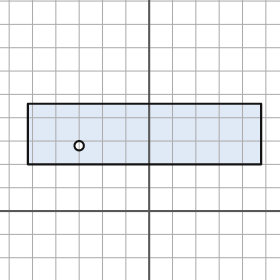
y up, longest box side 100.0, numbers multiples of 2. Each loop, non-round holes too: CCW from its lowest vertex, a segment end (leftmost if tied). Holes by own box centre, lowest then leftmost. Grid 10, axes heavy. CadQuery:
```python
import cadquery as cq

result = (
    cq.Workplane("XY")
    .moveTo(-52.0, 20.0)
    .lineTo(48.0, 20.0)
    .lineTo(48.0, 46.0)
    .lineTo(-52.0, 46.0)
    .close()
    .moveTo(-30.0, 28.0)
    .circle(2.0)
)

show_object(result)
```